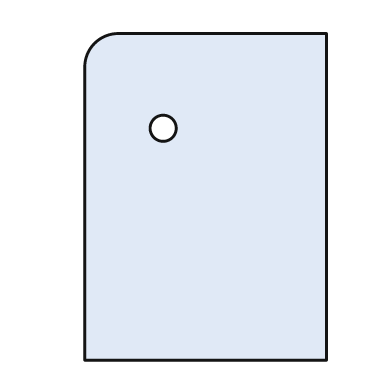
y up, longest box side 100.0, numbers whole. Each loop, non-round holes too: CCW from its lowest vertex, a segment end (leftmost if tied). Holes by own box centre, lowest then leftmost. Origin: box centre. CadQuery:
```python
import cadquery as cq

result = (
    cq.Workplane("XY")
    .moveTo(-37.0, -50.0)
    .lineTo(37.0, -50.0)
    .lineTo(37.0, 50.0)
    .lineTo(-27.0, 50.0)
    .threePointArc((-34.0, 47.0), (-37.0, 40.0))
    .close()
    .moveTo(-13.0, 21.0)
    .circle(4.0)
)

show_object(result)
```